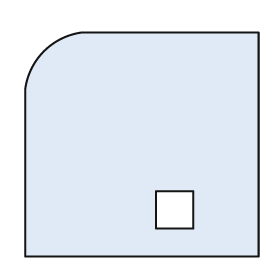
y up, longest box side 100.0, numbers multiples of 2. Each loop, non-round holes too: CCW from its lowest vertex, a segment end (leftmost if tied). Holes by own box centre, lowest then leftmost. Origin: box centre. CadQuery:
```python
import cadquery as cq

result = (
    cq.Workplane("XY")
    .moveTo(-50.0, -48.0)
    .lineTo(50.0, -48.0)
    .lineTo(50.0, 48.0)
    .lineTo(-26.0, 48.0)
    .threePointArc((-42.0, 40.0), (-50.0, 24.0))
    .close()
    .moveTo(6.0, -36.0)
    .lineTo(22.0, -36.0)
    .lineTo(22.0, -20.0)
    .lineTo(6.0, -20.0)
    .close()
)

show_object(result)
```